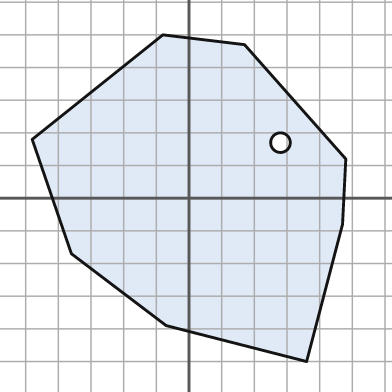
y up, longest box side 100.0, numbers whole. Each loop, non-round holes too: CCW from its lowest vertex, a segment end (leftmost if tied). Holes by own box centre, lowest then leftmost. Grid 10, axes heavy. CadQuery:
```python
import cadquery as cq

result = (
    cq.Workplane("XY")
    .moveTo(36.0, -50.0)
    .lineTo(47.0, -8.0)
    .lineTo(48.0, 12.0)
    .lineTo(17.0, 47.0)
    .lineTo(-8.0, 50.0)
    .lineTo(-48.0, 18.0)
    .lineTo(-36.0, -17.0)
    .lineTo(-7.0, -39.0)
    .close()
    .moveTo(28.0, 17.0)
    .circle(3.0)
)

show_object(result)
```